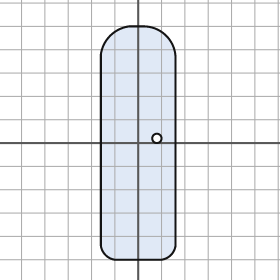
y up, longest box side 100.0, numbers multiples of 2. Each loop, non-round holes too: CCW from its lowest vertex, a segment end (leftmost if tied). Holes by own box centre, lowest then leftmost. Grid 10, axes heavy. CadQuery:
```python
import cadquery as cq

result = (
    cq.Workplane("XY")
    .moveTo(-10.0, -50.0)
    .lineTo(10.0, -50.0)
    .threePointArc((14.0, -48.0), (16.0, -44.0))
    .lineTo(16.0, 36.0)
    .threePointArc((12.0, 46.0), (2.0, 50.0))
    .lineTo(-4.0, 50.0)
    .threePointArc((-12.0, 46.0), (-16.0, 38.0))
    .lineTo(-16.0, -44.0)
    .threePointArc((-14.0, -48.0), (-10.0, -50.0))
    .close()
    .moveTo(8.0, 2.0)
    .circle(2.0)
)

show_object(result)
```